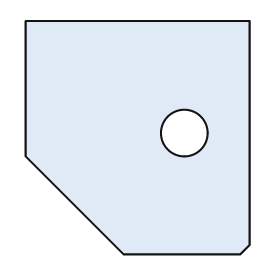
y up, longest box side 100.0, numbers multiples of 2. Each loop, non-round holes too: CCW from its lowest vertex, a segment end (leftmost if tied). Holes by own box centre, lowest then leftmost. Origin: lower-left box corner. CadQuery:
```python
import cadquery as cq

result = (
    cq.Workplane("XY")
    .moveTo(42.0, 0.0)
    .lineTo(92.0, 0.0)
    .lineTo(96.0, 4.0)
    .lineTo(96.0, 100.0)
    .lineTo(0.0, 100.0)
    .lineTo(0.0, 42.0)
    .close()
    .moveTo(68.0, 52.0)
    .circle(10.0)
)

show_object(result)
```